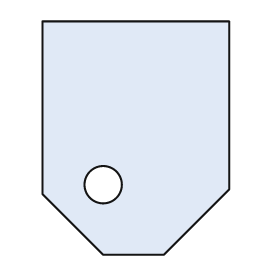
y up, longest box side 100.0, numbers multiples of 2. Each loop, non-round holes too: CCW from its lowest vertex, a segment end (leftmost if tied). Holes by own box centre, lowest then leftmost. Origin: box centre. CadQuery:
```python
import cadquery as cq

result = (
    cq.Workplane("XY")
    .moveTo(-14.0, -50.0)
    .lineTo(12.0, -50.0)
    .lineTo(40.0, -22.0)
    .lineTo(40.0, 50.0)
    .lineTo(-40.0, 50.0)
    .lineTo(-40.0, -24.0)
    .close()
    .moveTo(-14.0, -20.0)
    .circle(8.0)
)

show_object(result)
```